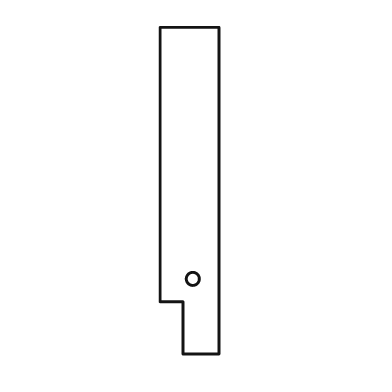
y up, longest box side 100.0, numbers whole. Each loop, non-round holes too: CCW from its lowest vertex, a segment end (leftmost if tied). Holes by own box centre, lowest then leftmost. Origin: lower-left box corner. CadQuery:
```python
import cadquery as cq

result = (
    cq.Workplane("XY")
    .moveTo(7.0, 0.0)
    .lineTo(18.0, 0.0)
    .lineTo(18.0, 100.0)
    .lineTo(0.0, 100.0)
    .lineTo(0.0, 16.0)
    .lineTo(7.0, 16.0)
    .close()
    .moveTo(10.0, 23.0)
    .circle(2.0)
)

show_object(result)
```